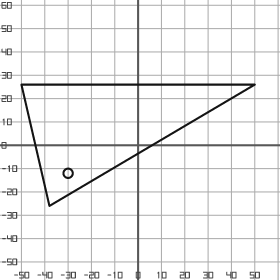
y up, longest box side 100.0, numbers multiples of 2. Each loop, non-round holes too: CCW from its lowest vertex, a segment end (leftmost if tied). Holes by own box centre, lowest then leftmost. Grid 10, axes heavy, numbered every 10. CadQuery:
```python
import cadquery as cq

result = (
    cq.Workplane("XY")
    .moveTo(-38.0, -26.0)
    .lineTo(50.0, 26.0)
    .lineTo(-50.0, 26.0)
    .close()
    .moveTo(-30.0, -12.0)
    .circle(2.0)
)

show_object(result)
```